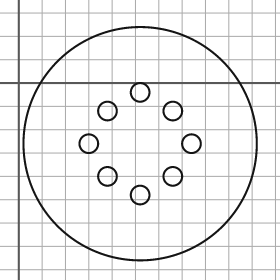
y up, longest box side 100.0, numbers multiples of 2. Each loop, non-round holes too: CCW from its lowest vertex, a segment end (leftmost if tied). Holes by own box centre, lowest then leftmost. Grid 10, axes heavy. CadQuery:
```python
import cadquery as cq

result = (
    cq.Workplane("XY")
    .moveTo(52.0, -26.0)
    .circle(50.0)
    .moveTo(52.0, -48.0)
    .circle(4.0)
    .moveTo(38.0, -40.0)
    .circle(4.0)
    .moveTo(66.0, -40.0)
    .circle(4.0)
    .moveTo(30.0, -26.0)
    .circle(4.0)
    .moveTo(74.0, -26.0)
    .circle(4.0)
    .moveTo(38.0, -12.0)
    .circle(4.0)
    .moveTo(66.0, -12.0)
    .circle(4.0)
    .moveTo(52.0, -4.0)
    .circle(4.0)
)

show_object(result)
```